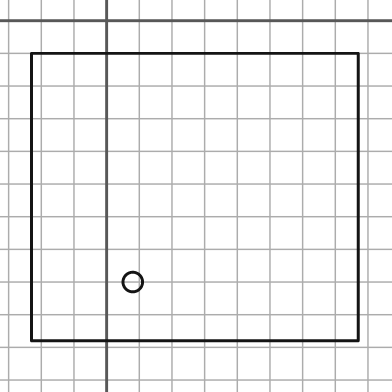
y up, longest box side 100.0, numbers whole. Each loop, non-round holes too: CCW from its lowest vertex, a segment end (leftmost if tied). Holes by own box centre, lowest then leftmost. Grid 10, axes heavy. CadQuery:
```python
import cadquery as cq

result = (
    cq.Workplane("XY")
    .moveTo(-23.0, -98.0)
    .lineTo(77.0, -98.0)
    .lineTo(77.0, -10.0)
    .lineTo(-23.0, -10.0)
    .close()
    .moveTo(8.0, -80.0)
    .circle(3.0)
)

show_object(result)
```